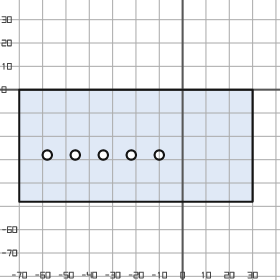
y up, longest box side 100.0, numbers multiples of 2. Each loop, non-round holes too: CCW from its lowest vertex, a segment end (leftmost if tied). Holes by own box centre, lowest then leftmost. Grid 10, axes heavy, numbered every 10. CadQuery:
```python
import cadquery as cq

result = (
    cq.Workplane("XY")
    .moveTo(-70.0, -48.0)
    .lineTo(30.0, -48.0)
    .lineTo(30.0, 0.0)
    .lineTo(-70.0, 0.0)
    .close()
    .moveTo(-58.0, -28.0)
    .circle(2.0)
    .moveTo(-46.0, -28.0)
    .circle(2.0)
    .moveTo(-34.0, -28.0)
    .circle(2.0)
    .moveTo(-22.0, -28.0)
    .circle(2.0)
    .moveTo(-10.0, -28.0)
    .circle(2.0)
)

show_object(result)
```